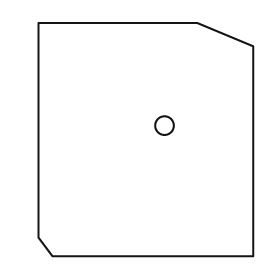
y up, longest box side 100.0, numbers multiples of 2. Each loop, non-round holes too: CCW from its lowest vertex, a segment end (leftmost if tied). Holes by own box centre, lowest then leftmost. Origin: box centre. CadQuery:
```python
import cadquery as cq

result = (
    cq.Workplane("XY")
    .moveTo(-40.0, -50.0)
    .lineTo(46.0, -50.0)
    .lineTo(46.0, 40.0)
    .lineTo(22.0, 50.0)
    .lineTo(-46.0, 50.0)
    .lineTo(-46.0, -42.0)
    .close()
    .moveTo(8.0, 6.0)
    .circle(4.0)
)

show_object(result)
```